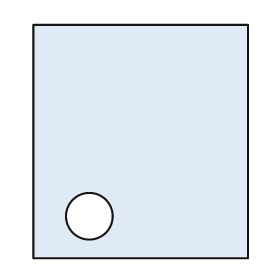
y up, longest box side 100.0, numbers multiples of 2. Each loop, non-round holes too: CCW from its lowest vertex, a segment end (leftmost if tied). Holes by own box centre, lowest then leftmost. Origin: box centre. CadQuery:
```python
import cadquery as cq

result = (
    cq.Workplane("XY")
    .moveTo(-46.0, -50.0)
    .lineTo(46.0, -50.0)
    .lineTo(46.0, 50.0)
    .lineTo(-46.0, 50.0)
    .close()
    .moveTo(-22.0, -32.0)
    .circle(10.0)
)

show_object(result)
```